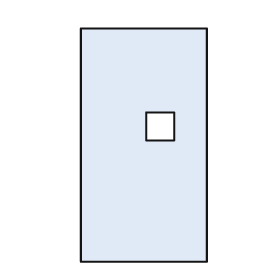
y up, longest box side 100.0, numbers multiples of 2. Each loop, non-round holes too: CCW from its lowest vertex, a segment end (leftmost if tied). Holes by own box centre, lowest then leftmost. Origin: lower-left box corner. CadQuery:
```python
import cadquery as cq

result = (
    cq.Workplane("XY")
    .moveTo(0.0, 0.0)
    .lineTo(54.0, 0.0)
    .lineTo(54.0, 100.0)
    .lineTo(0.0, 100.0)
    .close()
    .moveTo(28.0, 52.0)
    .lineTo(40.0, 52.0)
    .lineTo(40.0, 64.0)
    .lineTo(28.0, 64.0)
    .close()
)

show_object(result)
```